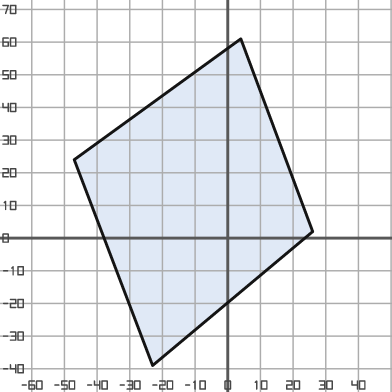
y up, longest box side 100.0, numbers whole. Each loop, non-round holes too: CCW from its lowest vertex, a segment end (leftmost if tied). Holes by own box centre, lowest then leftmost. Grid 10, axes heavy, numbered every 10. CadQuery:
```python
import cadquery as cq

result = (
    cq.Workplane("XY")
    .moveTo(-23.0, -39.0)
    .lineTo(26.0, 2.0)
    .lineTo(4.0, 61.0)
    .lineTo(-47.0, 24.0)
    .close()
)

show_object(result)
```